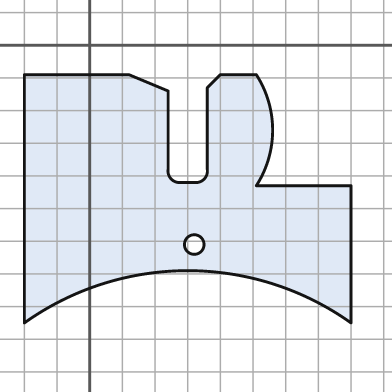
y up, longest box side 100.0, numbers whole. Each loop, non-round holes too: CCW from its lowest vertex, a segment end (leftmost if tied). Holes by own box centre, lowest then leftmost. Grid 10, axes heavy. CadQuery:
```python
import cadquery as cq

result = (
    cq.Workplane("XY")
    .moveTo(-20.0, -85.0)
    .threePointArc((30.0, -69.0), (80.0, -85.0))
    .lineTo(80.0, -43.0)
    .lineTo(51.0, -43.0)
    .threePointArc((56.0, -26.0), (51.0, -9.0))
    .lineTo(40.0, -9.0)
    .lineTo(36.0, -13.0)
    .lineTo(36.0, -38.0)
    .threePointArc((35.0, -41.0), (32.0, -42.0))
    .lineTo(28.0, -42.0)
    .threePointArc((25.0, -41.0), (24.0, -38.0))
    .lineTo(24.0, -14.0)
    .lineTo(12.0, -9.0)
    .lineTo(-20.0, -9.0)
    .close()
    .moveTo(32.0, -61.0)
    .circle(3.0)
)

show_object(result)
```